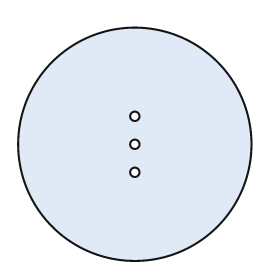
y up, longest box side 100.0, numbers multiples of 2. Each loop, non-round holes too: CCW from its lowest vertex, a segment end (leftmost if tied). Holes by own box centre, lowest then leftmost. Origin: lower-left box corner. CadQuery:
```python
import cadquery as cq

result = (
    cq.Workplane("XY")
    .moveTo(50.0, 50.0)
    .circle(50.0)
    .moveTo(50.0, 38.0)
    .circle(2.0)
    .moveTo(50.0, 50.0)
    .circle(2.0)
    .moveTo(50.0, 62.0)
    .circle(2.0)
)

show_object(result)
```